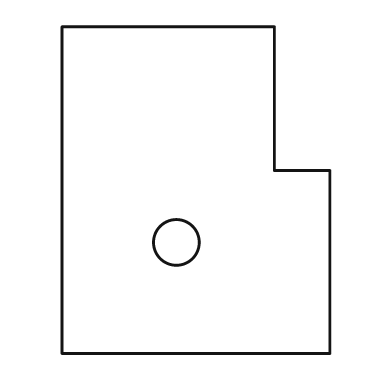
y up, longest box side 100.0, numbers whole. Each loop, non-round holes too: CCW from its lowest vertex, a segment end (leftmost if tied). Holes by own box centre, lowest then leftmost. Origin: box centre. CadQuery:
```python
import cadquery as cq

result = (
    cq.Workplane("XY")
    .moveTo(-41.0, -50.0)
    .lineTo(41.0, -50.0)
    .lineTo(41.0, 6.0)
    .lineTo(24.0, 6.0)
    .lineTo(24.0, 50.0)
    .lineTo(-41.0, 50.0)
    .close()
    .moveTo(-6.0, -16.0)
    .circle(7.0)
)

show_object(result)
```